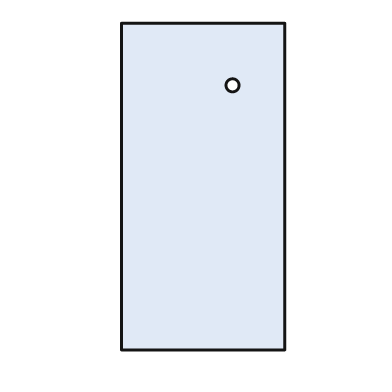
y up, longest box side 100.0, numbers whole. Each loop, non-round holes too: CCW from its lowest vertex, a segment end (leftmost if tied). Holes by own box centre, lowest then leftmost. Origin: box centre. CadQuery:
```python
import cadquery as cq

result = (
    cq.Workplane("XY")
    .moveTo(-25.0, -50.0)
    .lineTo(25.0, -50.0)
    .lineTo(25.0, 50.0)
    .lineTo(-25.0, 50.0)
    .close()
    .moveTo(9.0, 31.0)
    .circle(2.0)
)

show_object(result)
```